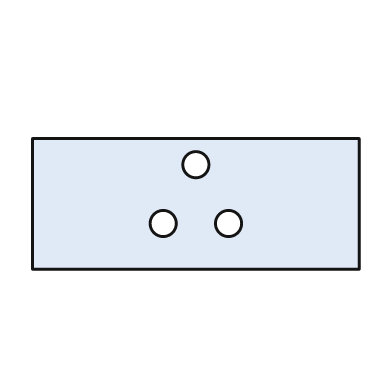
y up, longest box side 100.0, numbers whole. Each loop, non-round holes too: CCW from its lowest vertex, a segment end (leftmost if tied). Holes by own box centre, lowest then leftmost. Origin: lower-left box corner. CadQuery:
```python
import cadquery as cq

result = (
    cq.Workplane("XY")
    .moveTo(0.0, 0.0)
    .lineTo(100.0, 0.0)
    .lineTo(100.0, 40.0)
    .lineTo(0.0, 40.0)
    .close()
    .moveTo(40.0, 14.0)
    .circle(4.0)
    .moveTo(60.0, 14.0)
    .circle(4.0)
    .moveTo(50.0, 32.0)
    .circle(4.0)
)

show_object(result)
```